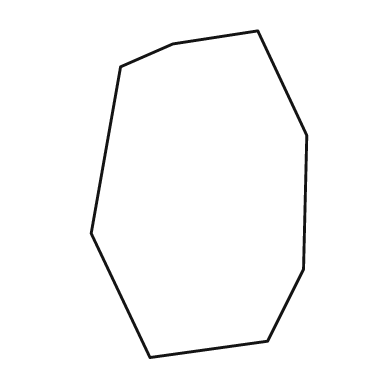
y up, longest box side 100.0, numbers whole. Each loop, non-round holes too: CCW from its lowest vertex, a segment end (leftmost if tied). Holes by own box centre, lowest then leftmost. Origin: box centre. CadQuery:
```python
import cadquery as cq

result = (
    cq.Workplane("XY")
    .moveTo(-15.0, -50.0)
    .lineTo(21.0, -45.0)
    .lineTo(32.0, -23.0)
    .lineTo(33.0, 18.0)
    .lineTo(18.0, 50.0)
    .lineTo(-8.0, 46.0)
    .lineTo(-24.0, 39.0)
    .lineTo(-33.0, -12.0)
    .close()
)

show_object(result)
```